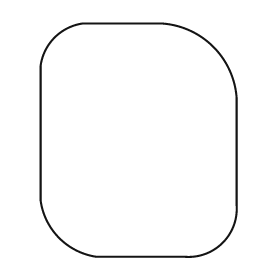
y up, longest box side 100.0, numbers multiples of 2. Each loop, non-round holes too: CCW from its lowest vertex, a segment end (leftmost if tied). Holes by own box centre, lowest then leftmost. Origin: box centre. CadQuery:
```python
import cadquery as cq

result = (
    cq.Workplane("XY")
    .moveTo(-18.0, -50.0)
    .lineTo(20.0, -50.0)
    .threePointArc((36.0, -44.0), (42.0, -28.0))
    .lineTo(42.0, 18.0)
    .threePointArc((32.0, 40.0), (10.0, 50.0))
    .lineTo(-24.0, 50.0)
    .threePointArc((-36.0, 44.0), (-42.0, 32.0))
    .lineTo(-42.0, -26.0)
    .threePointArc((-34.0, -42.0), (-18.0, -50.0))
    .close()
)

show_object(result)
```